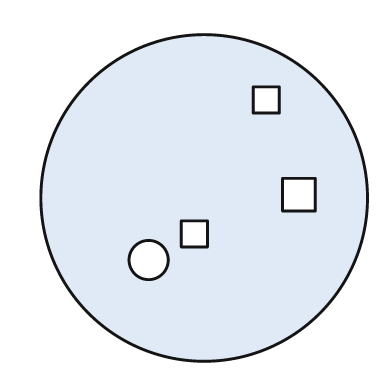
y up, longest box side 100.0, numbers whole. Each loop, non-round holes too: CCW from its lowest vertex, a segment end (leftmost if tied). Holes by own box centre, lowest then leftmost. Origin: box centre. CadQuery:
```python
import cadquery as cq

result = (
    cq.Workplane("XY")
    .moveTo(0.0, 0.0)
    .circle(50.0)
    .moveTo(-17.0, -19.0)
    .circle(6.0)
    .moveTo(-7.0, -15.0)
    .lineTo(1.0, -15.0)
    .lineTo(1.0, -7.0)
    .lineTo(-7.0, -7.0)
    .close()
    .moveTo(24.0, -4.0)
    .lineTo(34.0, -4.0)
    .lineTo(34.0, 6.0)
    .lineTo(24.0, 6.0)
    .close()
    .moveTo(15.0, 26.0)
    .lineTo(23.0, 26.0)
    .lineTo(23.0, 34.0)
    .lineTo(15.0, 34.0)
    .close()
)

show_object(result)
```